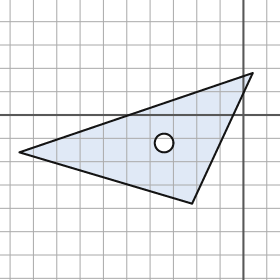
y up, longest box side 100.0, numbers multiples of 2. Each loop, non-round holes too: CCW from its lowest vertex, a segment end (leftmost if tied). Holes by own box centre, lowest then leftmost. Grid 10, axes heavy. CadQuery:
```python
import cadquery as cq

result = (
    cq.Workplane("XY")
    .moveTo(-22.0, -38.0)
    .lineTo(4.0, 18.0)
    .lineTo(-96.0, -16.0)
    .close()
    .moveTo(-34.0, -12.0)
    .circle(4.0)
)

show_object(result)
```